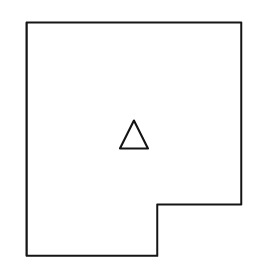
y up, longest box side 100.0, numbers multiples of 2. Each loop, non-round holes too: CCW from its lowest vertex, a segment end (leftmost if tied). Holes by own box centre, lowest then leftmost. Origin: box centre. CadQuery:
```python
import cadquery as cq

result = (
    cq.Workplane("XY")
    .moveTo(-46.0, -50.0)
    .lineTo(10.0, -50.0)
    .lineTo(10.0, -28.0)
    .lineTo(46.0, -28.0)
    .lineTo(46.0, 50.0)
    .lineTo(-46.0, 50.0)
    .close()
    .moveTo(-6.0, -4.0)
    .lineTo(6.0, -4.0)
    .lineTo(0.0, 8.0)
    .close()
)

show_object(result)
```